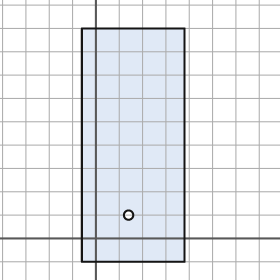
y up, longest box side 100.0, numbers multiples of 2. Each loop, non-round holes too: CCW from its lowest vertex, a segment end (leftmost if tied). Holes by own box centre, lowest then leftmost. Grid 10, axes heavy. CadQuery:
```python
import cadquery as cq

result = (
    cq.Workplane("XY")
    .moveTo(-6.0, -10.0)
    .lineTo(38.0, -10.0)
    .lineTo(38.0, 90.0)
    .lineTo(-6.0, 90.0)
    .close()
    .moveTo(14.0, 10.0)
    .circle(2.0)
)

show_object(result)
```